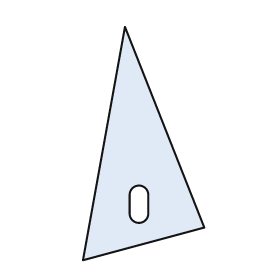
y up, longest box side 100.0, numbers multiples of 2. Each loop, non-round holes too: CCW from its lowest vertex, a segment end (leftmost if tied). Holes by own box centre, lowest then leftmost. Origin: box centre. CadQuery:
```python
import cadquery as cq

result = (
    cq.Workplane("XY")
    .moveTo(-26.0, -50.0)
    .lineTo(26.0, -36.0)
    .lineTo(-8.0, 50.0)
    .close()
    .moveTo(-6.0, -30.0)
    .threePointArc((-2.0, -34.0), (2.0, -30.0))
    .lineTo(2.0, -22.0)
    .threePointArc((-2.0, -18.0), (-6.0, -22.0))
    .close()
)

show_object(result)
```